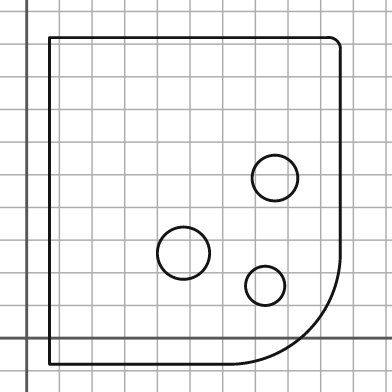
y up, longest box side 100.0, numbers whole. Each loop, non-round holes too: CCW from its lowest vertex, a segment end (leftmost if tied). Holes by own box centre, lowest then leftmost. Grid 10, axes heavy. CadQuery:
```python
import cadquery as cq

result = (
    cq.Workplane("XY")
    .moveTo(7.0, -8.0)
    .lineTo(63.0, -8.0)
    .threePointArc((86.0, 2.0), (96.0, 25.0))
    .lineTo(96.0, 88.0)
    .threePointArc((95.0, 91.0), (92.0, 92.0))
    .lineTo(7.0, 92.0)
    .close()
    .moveTo(73.0, 16.0)
    .circle(6.0)
    .moveTo(48.0, 26.0)
    .circle(8.0)
    .moveTo(76.0, 49.0)
    .circle(7.0)
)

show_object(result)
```